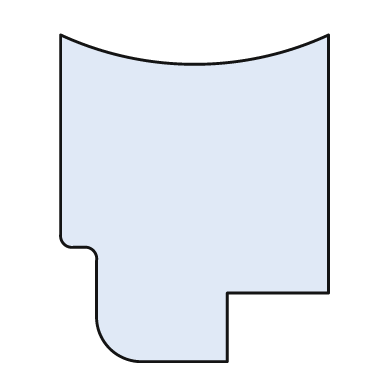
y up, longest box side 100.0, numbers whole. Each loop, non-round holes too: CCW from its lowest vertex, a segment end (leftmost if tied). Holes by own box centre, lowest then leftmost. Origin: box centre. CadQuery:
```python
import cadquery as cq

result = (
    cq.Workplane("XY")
    .moveTo(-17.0, -50.0)
    .lineTo(10.0, -50.0)
    .lineTo(10.0, -29.0)
    .lineTo(41.0, -29.0)
    .lineTo(41.0, 50.0)
    .threePointArc((0.0, 41.0), (-41.0, 50.0))
    .lineTo(-41.0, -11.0)
    .threePointArc((-40.0, -14.0), (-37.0, -15.0))
    .lineTo(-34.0, -15.0)
    .threePointArc((-31.0, -16.0), (-30.0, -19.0))
    .lineTo(-30.0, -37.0)
    .threePointArc((-26.0, -46.0), (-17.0, -50.0))
    .close()
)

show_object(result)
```